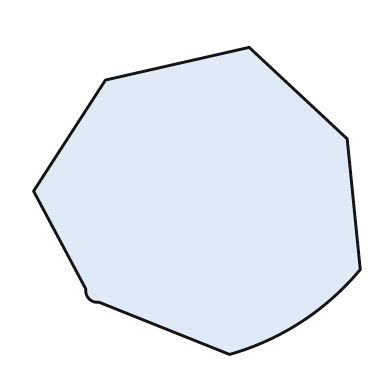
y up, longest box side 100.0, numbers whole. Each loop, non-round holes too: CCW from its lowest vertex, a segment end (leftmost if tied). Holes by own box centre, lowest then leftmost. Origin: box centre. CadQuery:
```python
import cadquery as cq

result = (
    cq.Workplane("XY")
    .moveTo(10.0, -47.0)
    .threePointArc((32.0, -37.0), (50.0, -21.0))
    .lineTo(46.0, 19.0)
    .lineTo(16.0, 47.0)
    .lineTo(-28.0, 37.0)
    .lineTo(-50.0, 3.0)
    .lineTo(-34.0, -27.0)
    .threePointArc((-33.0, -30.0), (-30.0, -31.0))
    .close()
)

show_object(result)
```